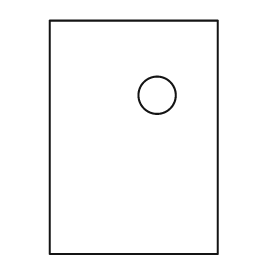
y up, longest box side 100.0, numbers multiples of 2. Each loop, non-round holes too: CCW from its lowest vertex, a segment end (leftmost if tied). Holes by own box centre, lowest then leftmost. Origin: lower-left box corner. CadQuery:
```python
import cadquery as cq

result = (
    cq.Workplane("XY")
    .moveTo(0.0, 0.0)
    .lineTo(72.0, 0.0)
    .lineTo(72.0, 100.0)
    .lineTo(0.0, 100.0)
    .close()
    .moveTo(46.0, 68.0)
    .circle(8.0)
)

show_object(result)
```